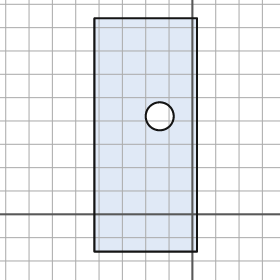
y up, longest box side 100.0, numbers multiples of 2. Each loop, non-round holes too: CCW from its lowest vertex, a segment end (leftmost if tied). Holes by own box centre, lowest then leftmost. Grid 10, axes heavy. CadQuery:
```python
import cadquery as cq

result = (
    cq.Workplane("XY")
    .moveTo(-42.0, -16.0)
    .lineTo(2.0, -16.0)
    .lineTo(2.0, 84.0)
    .lineTo(-42.0, 84.0)
    .close()
    .moveTo(-14.0, 42.0)
    .circle(6.0)
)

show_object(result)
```